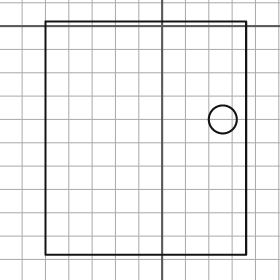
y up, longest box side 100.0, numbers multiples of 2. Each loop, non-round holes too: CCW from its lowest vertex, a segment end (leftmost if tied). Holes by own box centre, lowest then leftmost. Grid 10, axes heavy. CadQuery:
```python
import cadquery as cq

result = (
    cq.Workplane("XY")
    .moveTo(-50.0, -98.0)
    .lineTo(36.0, -98.0)
    .lineTo(36.0, 2.0)
    .lineTo(-50.0, 2.0)
    .close()
    .moveTo(26.0, -40.0)
    .circle(6.0)
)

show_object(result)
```